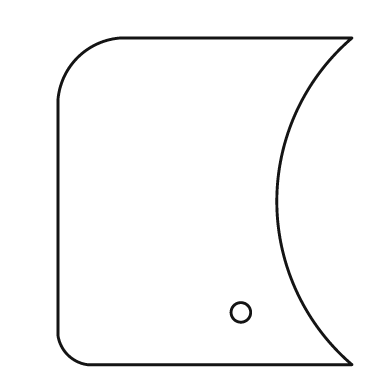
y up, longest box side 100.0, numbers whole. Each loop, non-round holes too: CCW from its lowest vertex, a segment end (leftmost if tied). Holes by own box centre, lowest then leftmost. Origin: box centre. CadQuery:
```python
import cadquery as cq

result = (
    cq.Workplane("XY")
    .moveTo(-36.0, -50.0)
    .lineTo(45.0, -50.0)
    .threePointArc((22.0, 0.0), (45.0, 50.0))
    .lineTo(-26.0, 50.0)
    .threePointArc((-39.0, 44.0), (-45.0, 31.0))
    .lineTo(-45.0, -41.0)
    .threePointArc((-42.0, -47.0), (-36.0, -50.0))
    .close()
    .moveTo(11.0, -34.0)
    .circle(3.0)
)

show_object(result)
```